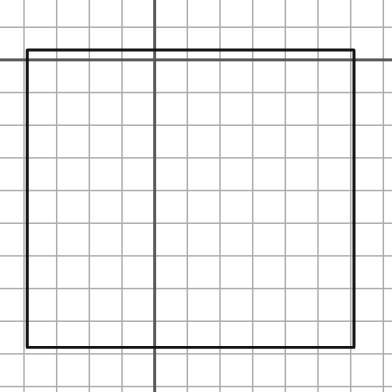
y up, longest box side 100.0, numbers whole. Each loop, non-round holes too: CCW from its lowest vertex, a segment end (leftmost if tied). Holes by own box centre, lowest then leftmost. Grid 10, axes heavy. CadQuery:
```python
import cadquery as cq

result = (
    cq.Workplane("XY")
    .moveTo(-39.0, -88.0)
    .lineTo(61.0, -88.0)
    .lineTo(61.0, 3.0)
    .lineTo(-39.0, 3.0)
    .close()
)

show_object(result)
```